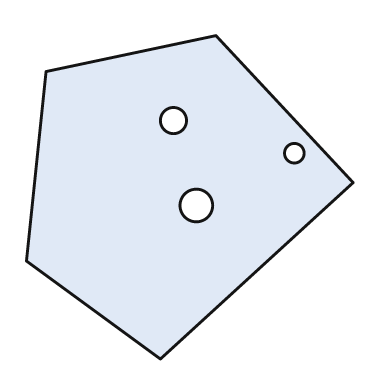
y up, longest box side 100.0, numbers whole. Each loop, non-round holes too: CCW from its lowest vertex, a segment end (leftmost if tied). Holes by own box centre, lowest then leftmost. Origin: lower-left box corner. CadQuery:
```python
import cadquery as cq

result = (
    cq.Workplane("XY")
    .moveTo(41.0, 0.0)
    .lineTo(100.0, 54.0)
    .lineTo(58.0, 99.0)
    .lineTo(6.0, 88.0)
    .lineTo(0.0, 30.0)
    .close()
    .moveTo(52.0, 47.0)
    .circle(5.0)
    .moveTo(82.0, 63.0)
    .circle(3.0)
    .moveTo(45.0, 73.0)
    .circle(4.0)
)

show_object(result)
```